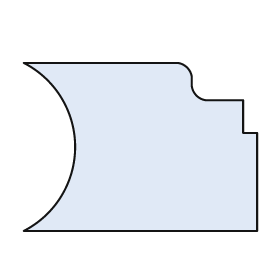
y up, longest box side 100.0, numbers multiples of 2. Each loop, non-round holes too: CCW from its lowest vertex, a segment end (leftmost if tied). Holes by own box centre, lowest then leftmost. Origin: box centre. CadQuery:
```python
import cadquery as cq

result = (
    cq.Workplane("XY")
    .moveTo(-50.0, -36.0)
    .lineTo(50.0, -36.0)
    .lineTo(50.0, 6.0)
    .lineTo(44.0, 6.0)
    .lineTo(44.0, 20.0)
    .lineTo(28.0, 20.0)
    .threePointArc((24.0, 22.0), (22.0, 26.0))
    .lineTo(22.0, 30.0)
    .threePointArc((20.0, 34.0), (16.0, 36.0))
    .lineTo(-50.0, 36.0)
    .threePointArc((-28.0, 0.0), (-50.0, -36.0))
    .close()
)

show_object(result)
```